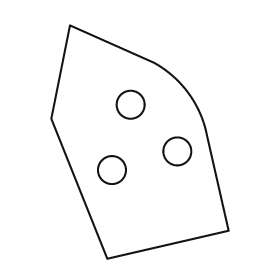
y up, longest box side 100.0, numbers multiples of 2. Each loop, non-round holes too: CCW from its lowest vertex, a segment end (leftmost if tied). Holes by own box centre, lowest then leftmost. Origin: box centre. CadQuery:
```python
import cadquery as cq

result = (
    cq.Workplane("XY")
    .moveTo(-14.0, -50.0)
    .lineTo(38.0, -38.0)
    .lineTo(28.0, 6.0)
    .threePointArc((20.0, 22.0), (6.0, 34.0))
    .lineTo(-30.0, 50.0)
    .lineTo(-38.0, 10.0)
    .close()
    .moveTo(-12.0, -12.0)
    .circle(6.0)
    .moveTo(16.0, -4.0)
    .circle(6.0)
    .moveTo(-4.0, 16.0)
    .circle(6.0)
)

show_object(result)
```